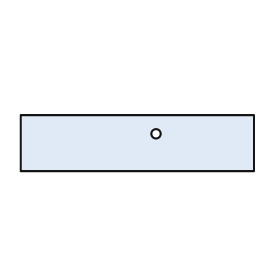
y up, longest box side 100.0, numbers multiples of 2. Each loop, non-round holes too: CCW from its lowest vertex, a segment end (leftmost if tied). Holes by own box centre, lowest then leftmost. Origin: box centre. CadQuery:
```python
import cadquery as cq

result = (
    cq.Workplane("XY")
    .moveTo(-50.0, -12.0)
    .lineTo(50.0, -12.0)
    .lineTo(50.0, 12.0)
    .lineTo(-50.0, 12.0)
    .close()
    .moveTo(8.0, 4.0)
    .circle(2.0)
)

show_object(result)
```